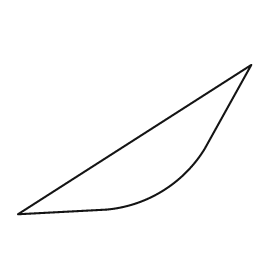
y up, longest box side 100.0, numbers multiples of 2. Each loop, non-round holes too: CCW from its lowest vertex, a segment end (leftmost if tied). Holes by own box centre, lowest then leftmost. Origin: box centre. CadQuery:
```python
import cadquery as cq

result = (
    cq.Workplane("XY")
    .moveTo(-50.0, -32.0)
    .lineTo(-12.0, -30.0)
    .threePointArc((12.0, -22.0), (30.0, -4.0))
    .lineTo(50.0, 32.0)
    .close()
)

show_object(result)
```